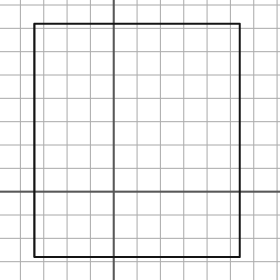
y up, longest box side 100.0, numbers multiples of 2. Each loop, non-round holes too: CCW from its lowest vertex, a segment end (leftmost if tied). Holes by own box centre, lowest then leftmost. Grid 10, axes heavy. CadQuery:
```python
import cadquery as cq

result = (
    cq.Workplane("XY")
    .moveTo(-34.0, -28.0)
    .lineTo(54.0, -28.0)
    .lineTo(54.0, 72.0)
    .lineTo(-34.0, 72.0)
    .close()
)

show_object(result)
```